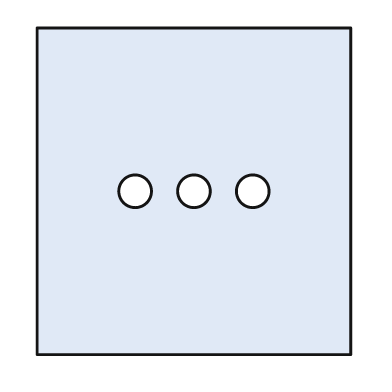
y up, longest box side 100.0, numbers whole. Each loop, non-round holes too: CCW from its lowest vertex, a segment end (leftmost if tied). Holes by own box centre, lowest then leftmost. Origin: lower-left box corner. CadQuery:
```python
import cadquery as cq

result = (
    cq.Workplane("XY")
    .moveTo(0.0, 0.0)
    .lineTo(96.0, 0.0)
    .lineTo(96.0, 100.0)
    .lineTo(0.0, 100.0)
    .close()
    .moveTo(30.0, 50.0)
    .circle(5.0)
    .moveTo(48.0, 50.0)
    .circle(5.0)
    .moveTo(66.0, 50.0)
    .circle(5.0)
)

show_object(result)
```